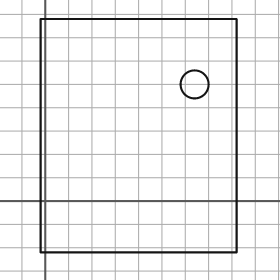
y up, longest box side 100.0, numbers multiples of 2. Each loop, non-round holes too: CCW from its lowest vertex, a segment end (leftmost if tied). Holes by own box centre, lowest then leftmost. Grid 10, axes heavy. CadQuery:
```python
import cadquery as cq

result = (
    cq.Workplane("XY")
    .moveTo(-2.0, -22.0)
    .lineTo(82.0, -22.0)
    .lineTo(82.0, 78.0)
    .lineTo(-2.0, 78.0)
    .close()
    .moveTo(64.0, 50.0)
    .circle(6.0)
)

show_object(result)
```